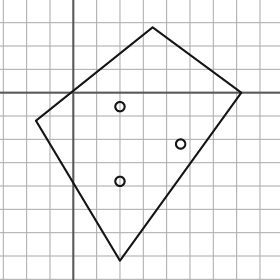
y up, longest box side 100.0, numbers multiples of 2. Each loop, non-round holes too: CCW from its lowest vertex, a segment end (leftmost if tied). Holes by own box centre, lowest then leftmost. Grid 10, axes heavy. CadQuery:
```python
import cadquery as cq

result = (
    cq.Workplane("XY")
    .moveTo(20.0, -72.0)
    .lineTo(72.0, 0.0)
    .lineTo(34.0, 28.0)
    .lineTo(-16.0, -12.0)
    .close()
    .moveTo(20.0, -38.0)
    .circle(2.0)
    .moveTo(46.0, -22.0)
    .circle(2.0)
    .moveTo(20.0, -6.0)
    .circle(2.0)
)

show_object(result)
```